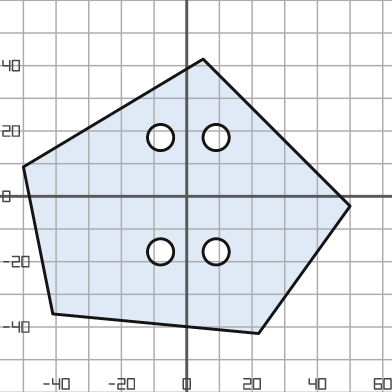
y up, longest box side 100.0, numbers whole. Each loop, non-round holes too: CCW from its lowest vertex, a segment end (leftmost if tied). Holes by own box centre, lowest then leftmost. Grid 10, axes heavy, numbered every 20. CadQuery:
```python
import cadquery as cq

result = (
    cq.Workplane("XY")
    .moveTo(22.0, -42.0)
    .lineTo(50.0, -3.0)
    .lineTo(5.0, 42.0)
    .lineTo(-50.0, 9.0)
    .lineTo(-41.0, -36.0)
    .close()
    .moveTo(-8.0, -17.0)
    .circle(4.0)
    .moveTo(9.0, -17.0)
    .circle(4.0)
    .moveTo(-8.0, 18.0)
    .circle(4.0)
    .moveTo(9.0, 18.0)
    .circle(4.0)
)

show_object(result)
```